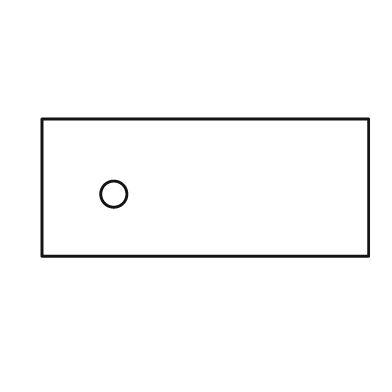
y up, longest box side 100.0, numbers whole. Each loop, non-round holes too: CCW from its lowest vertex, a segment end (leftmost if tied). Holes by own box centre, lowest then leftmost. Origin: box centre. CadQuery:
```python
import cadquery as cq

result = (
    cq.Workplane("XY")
    .moveTo(-50.0, -21.0)
    .lineTo(50.0, -21.0)
    .lineTo(50.0, 21.0)
    .lineTo(-50.0, 21.0)
    .close()
    .moveTo(-28.0, -2.0)
    .circle(4.0)
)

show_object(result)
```